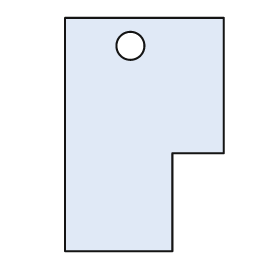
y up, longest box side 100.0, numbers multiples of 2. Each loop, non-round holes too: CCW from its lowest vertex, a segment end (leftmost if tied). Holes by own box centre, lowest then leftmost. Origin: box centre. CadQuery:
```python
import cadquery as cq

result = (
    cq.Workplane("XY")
    .moveTo(-34.0, -50.0)
    .lineTo(12.0, -50.0)
    .lineTo(12.0, -8.0)
    .lineTo(34.0, -8.0)
    .lineTo(34.0, 50.0)
    .lineTo(-34.0, 50.0)
    .close()
    .moveTo(-6.0, 38.0)
    .circle(6.0)
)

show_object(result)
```